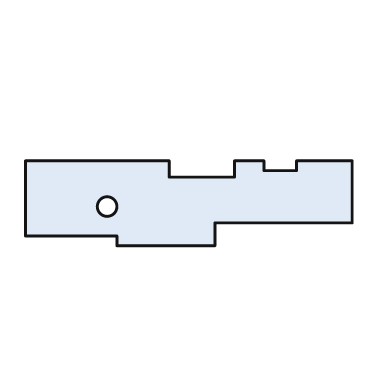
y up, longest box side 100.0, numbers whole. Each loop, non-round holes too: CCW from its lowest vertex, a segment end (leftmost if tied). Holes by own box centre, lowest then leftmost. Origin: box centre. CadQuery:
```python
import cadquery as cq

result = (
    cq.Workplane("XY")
    .moveTo(-22.0, -13.0)
    .lineTo(8.0, -13.0)
    .lineTo(8.0, -6.0)
    .lineTo(50.0, -6.0)
    .lineTo(50.0, 13.0)
    .lineTo(33.0, 13.0)
    .lineTo(33.0, 10.0)
    .lineTo(23.0, 10.0)
    .lineTo(23.0, 13.0)
    .lineTo(14.0, 13.0)
    .lineTo(14.0, 8.0)
    .lineTo(-6.0, 8.0)
    .lineTo(-6.0, 13.0)
    .lineTo(-50.0, 13.0)
    .lineTo(-50.0, -10.0)
    .lineTo(-22.0, -10.0)
    .close()
    .moveTo(-25.0, -1.0)
    .circle(3.0)
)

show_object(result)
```